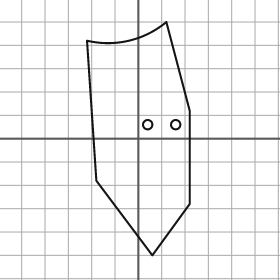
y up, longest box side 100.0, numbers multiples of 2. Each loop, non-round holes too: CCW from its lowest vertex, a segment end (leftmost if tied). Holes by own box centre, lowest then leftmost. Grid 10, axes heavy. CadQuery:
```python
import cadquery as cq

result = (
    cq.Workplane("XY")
    .moveTo(6.0, -50.0)
    .lineTo(22.0, -28.0)
    .lineTo(22.0, 12.0)
    .lineTo(12.0, 50.0)
    .threePointArc((-4.0, 42.0), (-22.0, 42.0))
    .lineTo(-18.0, -18.0)
    .close()
    .moveTo(4.0, 6.0)
    .circle(2.0)
    .moveTo(16.0, 6.0)
    .circle(2.0)
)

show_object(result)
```